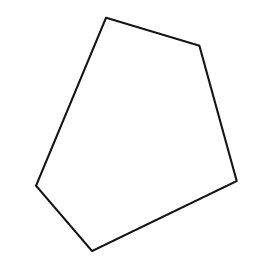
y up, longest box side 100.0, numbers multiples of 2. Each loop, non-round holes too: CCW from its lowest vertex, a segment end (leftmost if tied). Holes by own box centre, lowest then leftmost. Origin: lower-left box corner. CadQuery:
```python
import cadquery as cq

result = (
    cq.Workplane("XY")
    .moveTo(24.0, 0.0)
    .lineTo(86.0, 30.0)
    .lineTo(70.0, 88.0)
    .lineTo(30.0, 100.0)
    .lineTo(0.0, 28.0)
    .close()
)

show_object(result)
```